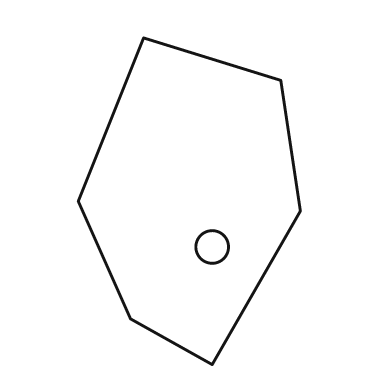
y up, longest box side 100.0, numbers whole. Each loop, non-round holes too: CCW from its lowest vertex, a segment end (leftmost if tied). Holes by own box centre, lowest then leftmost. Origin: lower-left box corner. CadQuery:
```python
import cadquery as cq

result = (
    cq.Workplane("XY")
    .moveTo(41.0, 0.0)
    .lineTo(68.0, 47.0)
    .lineTo(62.0, 87.0)
    .lineTo(20.0, 100.0)
    .lineTo(0.0, 50.0)
    .lineTo(16.0, 14.0)
    .close()
    .moveTo(41.0, 36.0)
    .circle(5.0)
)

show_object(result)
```